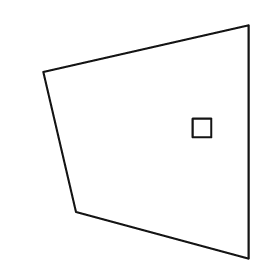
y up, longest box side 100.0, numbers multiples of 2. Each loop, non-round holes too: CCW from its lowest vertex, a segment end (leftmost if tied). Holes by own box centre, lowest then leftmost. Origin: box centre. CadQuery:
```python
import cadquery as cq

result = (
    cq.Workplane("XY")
    .moveTo(44.0, -50.0)
    .lineTo(44.0, 50.0)
    .lineTo(-44.0, 30.0)
    .lineTo(-30.0, -30.0)
    .close()
    .moveTo(20.0, 2.0)
    .lineTo(28.0, 2.0)
    .lineTo(28.0, 10.0)
    .lineTo(20.0, 10.0)
    .close()
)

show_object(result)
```